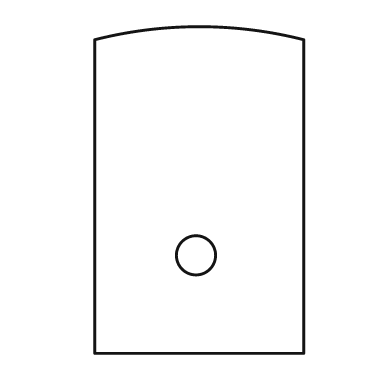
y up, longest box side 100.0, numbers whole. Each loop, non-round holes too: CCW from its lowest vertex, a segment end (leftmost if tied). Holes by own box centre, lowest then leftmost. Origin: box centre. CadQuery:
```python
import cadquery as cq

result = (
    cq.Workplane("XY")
    .moveTo(-32.0, -50.0)
    .lineTo(32.0, -50.0)
    .lineTo(32.0, 46.0)
    .threePointArc((0.0, 50.0), (-32.0, 46.0))
    .close()
    .moveTo(-1.0, -20.0)
    .circle(6.0)
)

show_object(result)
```